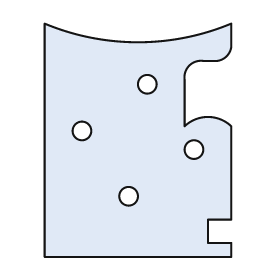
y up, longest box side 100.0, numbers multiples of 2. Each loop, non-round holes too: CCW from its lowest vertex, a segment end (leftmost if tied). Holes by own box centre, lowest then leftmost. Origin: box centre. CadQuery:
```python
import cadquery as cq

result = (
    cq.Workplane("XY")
    .moveTo(-40.0, -50.0)
    .lineTo(40.0, -50.0)
    .lineTo(40.0, -44.0)
    .lineTo(30.0, -44.0)
    .lineTo(30.0, -34.0)
    .lineTo(40.0, -34.0)
    .lineTo(40.0, 6.0)
    .threePointArc((30.0, 10.0), (20.0, 6.0))
    .lineTo(20.0, 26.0)
    .threePointArc((22.0, 32.0), (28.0, 34.0))
    .lineTo(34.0, 34.0)
    .threePointArc((38.0, 36.0), (40.0, 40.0))
    .lineTo(40.0, 50.0)
    .threePointArc((0.0, 42.0), (-40.0, 50.0))
    .close()
    .moveTo(-4.0, -24.0)
    .circle(4.0)
    .moveTo(24.0, -4.0)
    .circle(4.0)
    .moveTo(-24.0, 4.0)
    .circle(4.0)
    .moveTo(4.0, 24.0)
    .circle(4.0)
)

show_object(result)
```